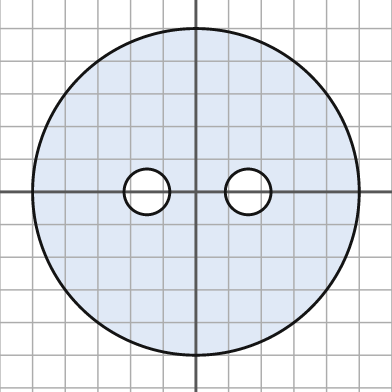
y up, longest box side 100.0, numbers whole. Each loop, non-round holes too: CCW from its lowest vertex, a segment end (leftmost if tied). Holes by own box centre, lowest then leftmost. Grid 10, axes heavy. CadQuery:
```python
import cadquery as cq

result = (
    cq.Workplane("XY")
    .moveTo(0.0, 0.0)
    .circle(50.0)
    .moveTo(-15.0, 0.0)
    .circle(7.0)
    .moveTo(16.0, 0.0)
    .circle(7.0)
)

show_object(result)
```